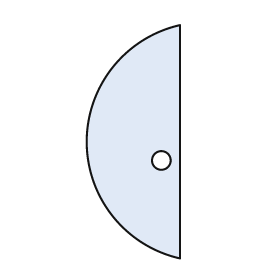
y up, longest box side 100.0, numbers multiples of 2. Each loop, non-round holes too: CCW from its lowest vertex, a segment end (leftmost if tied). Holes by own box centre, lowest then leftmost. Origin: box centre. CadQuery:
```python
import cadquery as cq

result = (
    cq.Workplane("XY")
    .moveTo(20.0, -50.0)
    .lineTo(20.0, 50.0)
    .threePointArc((-20.0, 0.0), (20.0, -50.0))
    .close()
    .moveTo(12.0, -8.0)
    .circle(4.0)
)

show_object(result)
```